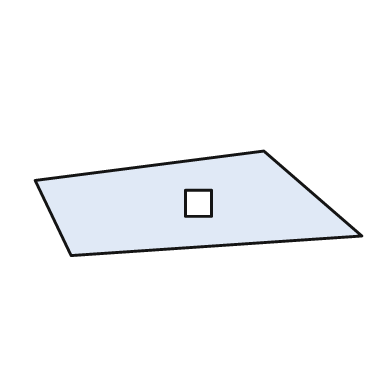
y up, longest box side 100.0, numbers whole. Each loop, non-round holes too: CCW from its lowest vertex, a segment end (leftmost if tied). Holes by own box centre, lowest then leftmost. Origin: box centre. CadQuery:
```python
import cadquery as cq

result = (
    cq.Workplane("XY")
    .moveTo(-39.0, -16.0)
    .lineTo(50.0, -10.0)
    .lineTo(20.0, 16.0)
    .lineTo(-50.0, 7.0)
    .close()
    .moveTo(-4.0, -4.0)
    .lineTo(4.0, -4.0)
    .lineTo(4.0, 4.0)
    .lineTo(-4.0, 4.0)
    .close()
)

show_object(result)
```